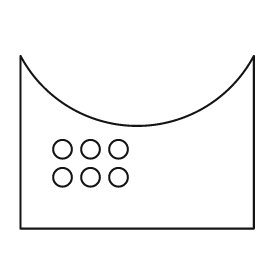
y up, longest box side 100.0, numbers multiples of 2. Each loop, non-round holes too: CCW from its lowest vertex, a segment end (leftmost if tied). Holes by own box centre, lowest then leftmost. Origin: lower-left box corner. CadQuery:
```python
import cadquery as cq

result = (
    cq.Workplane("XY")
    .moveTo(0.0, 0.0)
    .lineTo(100.0, 0.0)
    .lineTo(100.0, 74.0)
    .threePointArc((50.0, 44.0), (0.0, 74.0))
    .close()
    .moveTo(18.0, 22.0)
    .circle(4.0)
    .moveTo(30.0, 22.0)
    .circle(4.0)
    .moveTo(42.0, 22.0)
    .circle(4.0)
    .moveTo(18.0, 34.0)
    .circle(4.0)
    .moveTo(30.0, 34.0)
    .circle(4.0)
    .moveTo(42.0, 34.0)
    .circle(4.0)
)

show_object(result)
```